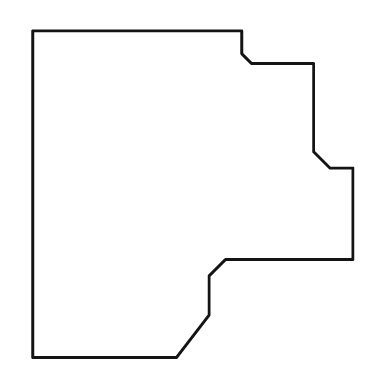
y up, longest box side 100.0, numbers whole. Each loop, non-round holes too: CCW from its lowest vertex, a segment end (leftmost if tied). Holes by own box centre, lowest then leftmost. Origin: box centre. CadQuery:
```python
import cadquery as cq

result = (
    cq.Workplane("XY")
    .moveTo(-49.0, -50.0)
    .lineTo(-5.0, -50.0)
    .lineTo(5.0, -37.0)
    .lineTo(5.0, -25.0)
    .lineTo(10.0, -20.0)
    .lineTo(49.0, -20.0)
    .lineTo(49.0, 8.0)
    .lineTo(42.0, 8.0)
    .lineTo(37.0, 13.0)
    .lineTo(37.0, 40.0)
    .lineTo(18.0, 40.0)
    .lineTo(15.0, 43.0)
    .lineTo(15.0, 50.0)
    .lineTo(-49.0, 50.0)
    .close()
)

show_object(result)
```